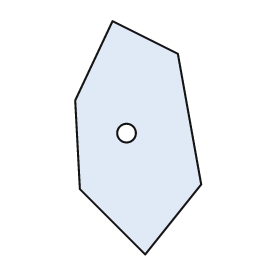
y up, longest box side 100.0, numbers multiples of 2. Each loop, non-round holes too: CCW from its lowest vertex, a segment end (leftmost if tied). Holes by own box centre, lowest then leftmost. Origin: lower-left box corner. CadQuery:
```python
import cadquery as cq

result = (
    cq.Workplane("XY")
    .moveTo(30.0, 0.0)
    .lineTo(54.0, 30.0)
    .lineTo(44.0, 86.0)
    .lineTo(16.0, 100.0)
    .lineTo(0.0, 66.0)
    .lineTo(2.0, 28.0)
    .close()
    .moveTo(22.0, 52.0)
    .circle(4.0)
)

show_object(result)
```